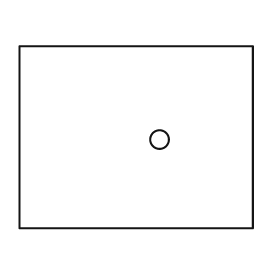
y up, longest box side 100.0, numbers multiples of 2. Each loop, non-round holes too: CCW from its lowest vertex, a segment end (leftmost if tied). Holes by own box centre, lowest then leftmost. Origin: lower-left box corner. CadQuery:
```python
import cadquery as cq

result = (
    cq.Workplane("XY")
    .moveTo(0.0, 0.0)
    .lineTo(100.0, 0.0)
    .lineTo(100.0, 78.0)
    .lineTo(0.0, 78.0)
    .close()
    .moveTo(60.0, 38.0)
    .circle(4.0)
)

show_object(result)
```